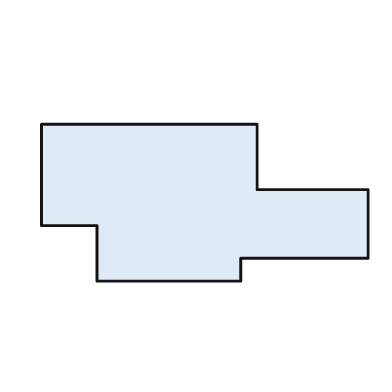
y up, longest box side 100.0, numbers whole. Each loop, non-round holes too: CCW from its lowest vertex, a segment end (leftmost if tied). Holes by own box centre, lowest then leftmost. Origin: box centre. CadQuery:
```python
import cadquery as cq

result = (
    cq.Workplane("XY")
    .moveTo(-33.0, -24.0)
    .lineTo(11.0, -24.0)
    .lineTo(11.0, -17.0)
    .lineTo(50.0, -17.0)
    .lineTo(50.0, 4.0)
    .lineTo(16.0, 4.0)
    .lineTo(16.0, 24.0)
    .lineTo(-50.0, 24.0)
    .lineTo(-50.0, -7.0)
    .lineTo(-33.0, -7.0)
    .close()
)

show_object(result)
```